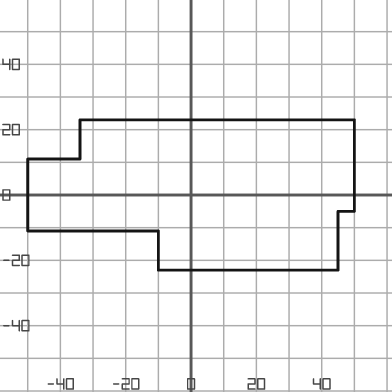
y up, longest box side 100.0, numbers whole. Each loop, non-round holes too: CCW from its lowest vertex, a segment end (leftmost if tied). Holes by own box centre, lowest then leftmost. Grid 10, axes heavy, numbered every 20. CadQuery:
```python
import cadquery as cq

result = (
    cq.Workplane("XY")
    .moveTo(-10.0, -23.0)
    .lineTo(45.0, -23.0)
    .lineTo(45.0, -5.0)
    .lineTo(50.0, -5.0)
    .lineTo(50.0, 23.0)
    .lineTo(-34.0, 23.0)
    .lineTo(-34.0, 11.0)
    .lineTo(-50.0, 11.0)
    .lineTo(-50.0, -11.0)
    .lineTo(-10.0, -11.0)
    .close()
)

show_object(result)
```